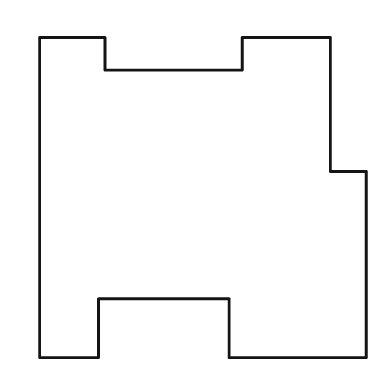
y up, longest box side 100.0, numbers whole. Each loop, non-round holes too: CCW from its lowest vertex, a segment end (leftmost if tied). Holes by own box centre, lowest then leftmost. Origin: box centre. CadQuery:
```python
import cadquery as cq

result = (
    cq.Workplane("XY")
    .moveTo(-50.0, -49.0)
    .lineTo(-32.0, -49.0)
    .lineTo(-32.0, -31.0)
    .lineTo(8.0, -31.0)
    .lineTo(8.0, -49.0)
    .lineTo(50.0, -49.0)
    .lineTo(50.0, 8.0)
    .lineTo(39.0, 8.0)
    .lineTo(39.0, 49.0)
    .lineTo(12.0, 49.0)
    .lineTo(12.0, 39.0)
    .lineTo(-30.0, 39.0)
    .lineTo(-30.0, 49.0)
    .lineTo(-50.0, 49.0)
    .close()
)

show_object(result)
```